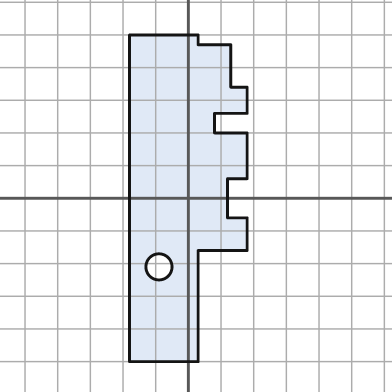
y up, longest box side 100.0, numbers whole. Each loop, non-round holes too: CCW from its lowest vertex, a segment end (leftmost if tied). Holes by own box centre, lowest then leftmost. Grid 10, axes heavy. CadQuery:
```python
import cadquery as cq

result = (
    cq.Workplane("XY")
    .moveTo(-18.0, -50.0)
    .lineTo(3.0, -50.0)
    .lineTo(3.0, -16.0)
    .lineTo(18.0, -16.0)
    .lineTo(18.0, -6.0)
    .lineTo(12.0, -6.0)
    .lineTo(12.0, 6.0)
    .lineTo(18.0, 6.0)
    .lineTo(18.0, 20.0)
    .lineTo(8.0, 20.0)
    .lineTo(8.0, 26.0)
    .lineTo(18.0, 26.0)
    .lineTo(18.0, 34.0)
    .lineTo(13.0, 34.0)
    .lineTo(13.0, 47.0)
    .lineTo(3.0, 47.0)
    .lineTo(3.0, 50.0)
    .lineTo(-18.0, 50.0)
    .close()
    .moveTo(-9.0, -21.0)
    .circle(4.0)
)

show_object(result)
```